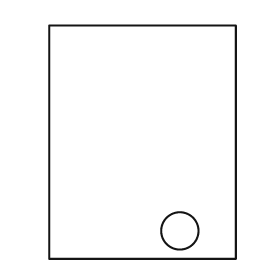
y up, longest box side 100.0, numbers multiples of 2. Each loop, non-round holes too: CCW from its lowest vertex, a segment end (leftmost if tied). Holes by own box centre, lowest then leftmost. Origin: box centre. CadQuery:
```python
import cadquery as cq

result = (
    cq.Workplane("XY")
    .moveTo(-40.0, -50.0)
    .lineTo(40.0, -50.0)
    .lineTo(40.0, 50.0)
    .lineTo(-40.0, 50.0)
    .close()
    .moveTo(16.0, -38.0)
    .circle(8.0)
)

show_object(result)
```